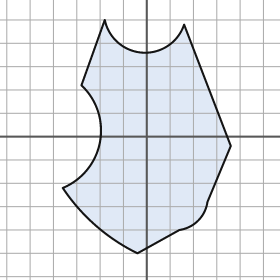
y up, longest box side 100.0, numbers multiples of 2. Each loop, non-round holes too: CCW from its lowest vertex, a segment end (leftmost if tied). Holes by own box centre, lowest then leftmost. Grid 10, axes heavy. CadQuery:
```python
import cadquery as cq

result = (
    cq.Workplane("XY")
    .moveTo(-4.0, -50.0)
    .lineTo(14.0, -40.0)
    .threePointArc((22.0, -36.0), (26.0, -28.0))
    .lineTo(36.0, -4.0)
    .lineTo(16.0, 48.0)
    .threePointArc((-2.0, 36.0), (-18.0, 50.0))
    .lineTo(-28.0, 22.0)
    .threePointArc((-20.0, -2.0), (-36.0, -22.0))
    .threePointArc((-22.0, -38.0), (-4.0, -50.0))
    .close()
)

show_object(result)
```